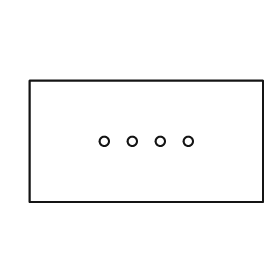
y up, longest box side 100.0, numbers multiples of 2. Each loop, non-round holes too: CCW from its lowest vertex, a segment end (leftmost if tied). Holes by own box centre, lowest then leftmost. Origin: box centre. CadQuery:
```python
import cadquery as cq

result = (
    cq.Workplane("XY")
    .moveTo(-50.0, -26.0)
    .lineTo(50.0, -26.0)
    .lineTo(50.0, 26.0)
    .lineTo(-50.0, 26.0)
    .close()
    .moveTo(-18.0, 0.0)
    .circle(2.0)
    .moveTo(-6.0, 0.0)
    .circle(2.0)
    .moveTo(6.0, 0.0)
    .circle(2.0)
    .moveTo(18.0, 0.0)
    .circle(2.0)
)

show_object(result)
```